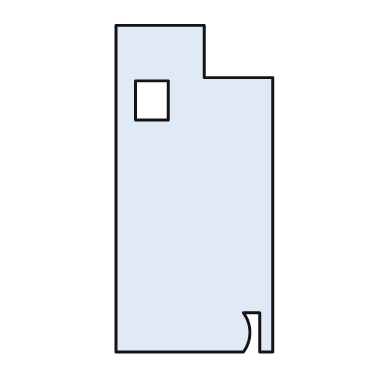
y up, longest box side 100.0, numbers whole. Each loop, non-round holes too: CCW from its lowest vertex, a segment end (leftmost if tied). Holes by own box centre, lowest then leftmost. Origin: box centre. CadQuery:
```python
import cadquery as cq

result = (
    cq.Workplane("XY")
    .moveTo(-24.0, -50.0)
    .lineTo(15.0, -50.0)
    .threePointArc((17.0, -44.0), (15.0, -38.0))
    .lineTo(20.0, -38.0)
    .lineTo(20.0, -50.0)
    .lineTo(24.0, -50.0)
    .lineTo(24.0, 34.0)
    .lineTo(3.0, 34.0)
    .lineTo(3.0, 50.0)
    .lineTo(-24.0, 50.0)
    .close()
    .moveTo(-18.0, 21.0)
    .lineTo(-8.0, 21.0)
    .lineTo(-8.0, 33.0)
    .lineTo(-18.0, 33.0)
    .close()
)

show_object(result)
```